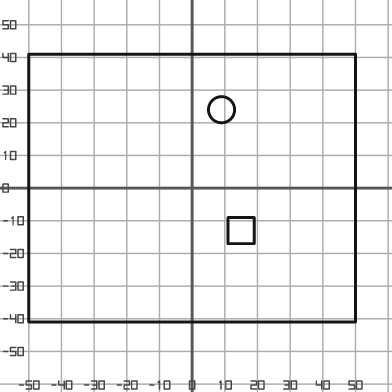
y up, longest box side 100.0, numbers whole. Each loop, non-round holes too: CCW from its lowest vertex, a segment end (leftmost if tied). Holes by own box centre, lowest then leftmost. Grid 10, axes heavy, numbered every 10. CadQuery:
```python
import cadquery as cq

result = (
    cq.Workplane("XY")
    .moveTo(-50.0, -41.0)
    .lineTo(50.0, -41.0)
    .lineTo(50.0, 41.0)
    .lineTo(-50.0, 41.0)
    .close()
    .moveTo(11.0, -17.0)
    .lineTo(19.0, -17.0)
    .lineTo(19.0, -9.0)
    .lineTo(11.0, -9.0)
    .close()
    .moveTo(9.0, 24.0)
    .circle(4.0)
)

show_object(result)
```